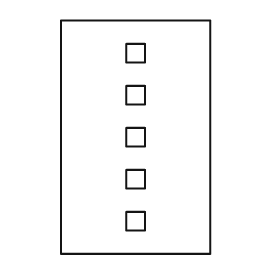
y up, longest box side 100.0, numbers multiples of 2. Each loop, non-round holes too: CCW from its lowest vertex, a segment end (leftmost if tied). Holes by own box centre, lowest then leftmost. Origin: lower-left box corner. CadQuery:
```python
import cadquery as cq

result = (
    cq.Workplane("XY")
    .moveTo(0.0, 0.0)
    .lineTo(64.0, 0.0)
    .lineTo(64.0, 100.0)
    .lineTo(0.0, 100.0)
    .close()
    .moveTo(28.0, 10.0)
    .lineTo(36.0, 10.0)
    .lineTo(36.0, 18.0)
    .lineTo(28.0, 18.0)
    .close()
    .moveTo(28.0, 28.0)
    .lineTo(36.0, 28.0)
    .lineTo(36.0, 36.0)
    .lineTo(28.0, 36.0)
    .close()
    .moveTo(28.0, 46.0)
    .lineTo(36.0, 46.0)
    .lineTo(36.0, 54.0)
    .lineTo(28.0, 54.0)
    .close()
    .moveTo(28.0, 64.0)
    .lineTo(36.0, 64.0)
    .lineTo(36.0, 72.0)
    .lineTo(28.0, 72.0)
    .close()
    .moveTo(28.0, 82.0)
    .lineTo(36.0, 82.0)
    .lineTo(36.0, 90.0)
    .lineTo(28.0, 90.0)
    .close()
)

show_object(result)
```